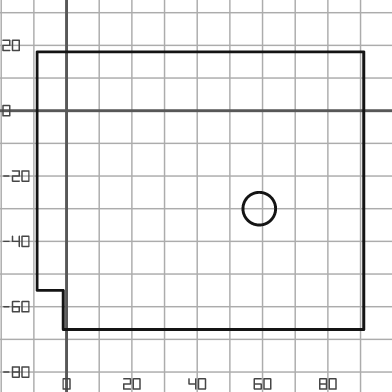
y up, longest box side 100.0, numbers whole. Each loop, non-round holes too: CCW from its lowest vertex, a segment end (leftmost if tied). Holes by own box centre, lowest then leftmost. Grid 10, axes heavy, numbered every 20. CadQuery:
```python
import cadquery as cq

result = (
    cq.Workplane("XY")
    .moveTo(-1.0, -67.0)
    .lineTo(91.0, -67.0)
    .lineTo(91.0, 18.0)
    .lineTo(-9.0, 18.0)
    .lineTo(-9.0, -55.0)
    .lineTo(-1.0, -55.0)
    .close()
    .moveTo(59.0, -30.0)
    .circle(5.0)
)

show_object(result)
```